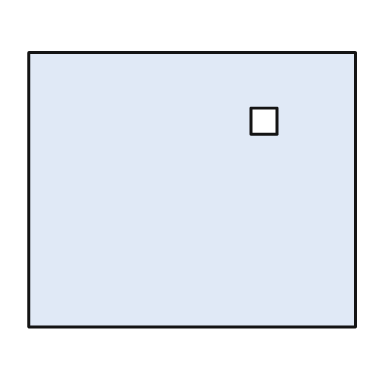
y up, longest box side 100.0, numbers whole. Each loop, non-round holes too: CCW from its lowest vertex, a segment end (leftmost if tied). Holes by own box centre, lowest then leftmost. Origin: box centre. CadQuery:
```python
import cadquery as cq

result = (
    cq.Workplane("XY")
    .moveTo(-50.0, -42.0)
    .lineTo(50.0, -42.0)
    .lineTo(50.0, 42.0)
    .lineTo(-50.0, 42.0)
    .close()
    .moveTo(18.0, 17.0)
    .lineTo(26.0, 17.0)
    .lineTo(26.0, 25.0)
    .lineTo(18.0, 25.0)
    .close()
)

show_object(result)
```